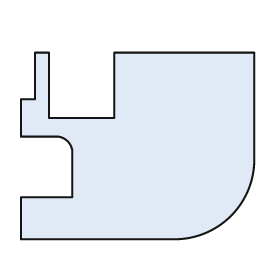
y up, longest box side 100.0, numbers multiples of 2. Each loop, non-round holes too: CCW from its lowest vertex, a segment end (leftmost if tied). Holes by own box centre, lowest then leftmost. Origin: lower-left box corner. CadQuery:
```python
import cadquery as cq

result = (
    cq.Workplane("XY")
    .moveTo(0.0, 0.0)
    .lineTo(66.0, 0.0)
    .threePointArc((90.0, 10.0), (100.0, 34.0))
    .lineTo(100.0, 80.0)
    .lineTo(40.0, 80.0)
    .lineTo(40.0, 52.0)
    .lineTo(12.0, 52.0)
    .lineTo(12.0, 80.0)
    .lineTo(6.0, 80.0)
    .lineTo(6.0, 60.0)
    .lineTo(0.0, 60.0)
    .lineTo(0.0, 44.0)
    .lineTo(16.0, 44.0)
    .threePointArc((20.0, 42.0), (22.0, 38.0))
    .lineTo(22.0, 18.0)
    .lineTo(0.0, 18.0)
    .close()
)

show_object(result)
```